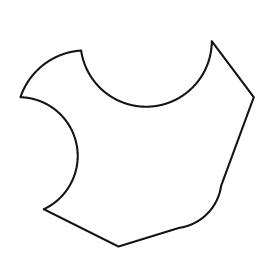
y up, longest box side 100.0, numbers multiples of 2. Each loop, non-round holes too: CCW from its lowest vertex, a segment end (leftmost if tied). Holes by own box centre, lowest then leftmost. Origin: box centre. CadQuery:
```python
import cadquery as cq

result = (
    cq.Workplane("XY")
    .moveTo(-8.0, -44.0)
    .lineTo(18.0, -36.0)
    .threePointArc((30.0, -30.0), (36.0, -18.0))
    .lineTo(50.0, 20.0)
    .lineTo(32.0, 44.0)
    .threePointArc((6.0, 16.0), (-24.0, 40.0))
    .threePointArc((-40.0, 34.0), (-50.0, 20.0))
    .threePointArc((-26.0, 0.0), (-40.0, -28.0))
    .close()
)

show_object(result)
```